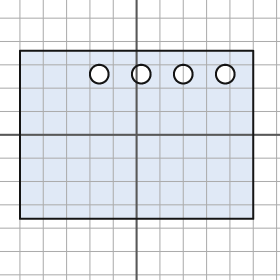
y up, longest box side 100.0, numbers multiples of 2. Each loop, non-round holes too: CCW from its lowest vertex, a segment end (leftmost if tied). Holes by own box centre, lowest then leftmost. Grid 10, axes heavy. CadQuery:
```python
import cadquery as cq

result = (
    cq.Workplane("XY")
    .moveTo(-50.0, -36.0)
    .lineTo(50.0, -36.0)
    .lineTo(50.0, 36.0)
    .lineTo(-50.0, 36.0)
    .close()
    .moveTo(-16.0, 26.0)
    .circle(4.0)
    .moveTo(2.0, 26.0)
    .circle(4.0)
    .moveTo(20.0, 26.0)
    .circle(4.0)
    .moveTo(38.0, 26.0)
    .circle(4.0)
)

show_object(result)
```